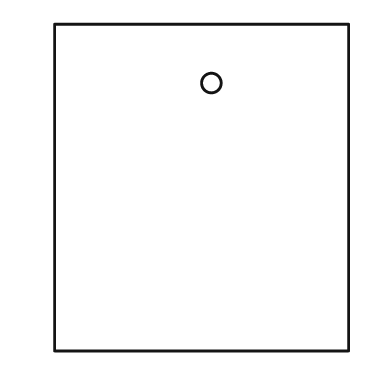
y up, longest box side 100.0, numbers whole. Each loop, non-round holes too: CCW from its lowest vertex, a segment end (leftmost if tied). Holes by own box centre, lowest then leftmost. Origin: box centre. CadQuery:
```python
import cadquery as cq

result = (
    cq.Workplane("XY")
    .moveTo(-45.0, -50.0)
    .lineTo(45.0, -50.0)
    .lineTo(45.0, 50.0)
    .lineTo(-45.0, 50.0)
    .close()
    .moveTo(3.0, 32.0)
    .circle(3.0)
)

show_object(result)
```